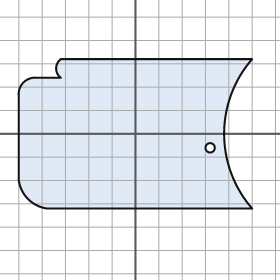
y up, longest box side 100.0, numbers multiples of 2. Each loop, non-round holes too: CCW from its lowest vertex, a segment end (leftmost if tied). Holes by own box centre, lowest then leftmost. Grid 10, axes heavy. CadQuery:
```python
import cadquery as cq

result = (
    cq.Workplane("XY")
    .moveTo(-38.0, -32.0)
    .lineTo(50.0, -32.0)
    .threePointArc((38.0, 0.0), (50.0, 32.0))
    .lineTo(-32.0, 32.0)
    .threePointArc((-34.0, 28.0), (-32.0, 24.0))
    .lineTo(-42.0, 24.0)
    .threePointArc((-48.0, 22.0), (-50.0, 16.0))
    .lineTo(-50.0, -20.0)
    .threePointArc((-46.0, -28.0), (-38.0, -32.0))
    .close()
    .moveTo(32.0, -6.0)
    .circle(2.0)
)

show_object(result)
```